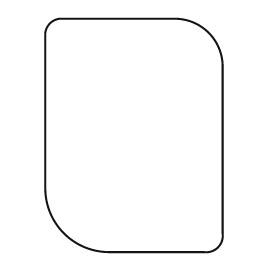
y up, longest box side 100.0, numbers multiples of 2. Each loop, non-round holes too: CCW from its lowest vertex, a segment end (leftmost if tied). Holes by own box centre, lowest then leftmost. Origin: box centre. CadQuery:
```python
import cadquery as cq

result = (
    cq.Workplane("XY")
    .moveTo(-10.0, -50.0)
    .lineTo(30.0, -50.0)
    .threePointArc((36.0, -48.0), (38.0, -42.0))
    .lineTo(38.0, 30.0)
    .threePointArc((32.0, 44.0), (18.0, 50.0))
    .lineTo(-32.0, 50.0)
    .threePointArc((-36.0, 48.0), (-38.0, 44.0))
    .lineTo(-38.0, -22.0)
    .threePointArc((-30.0, -42.0), (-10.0, -50.0))
    .close()
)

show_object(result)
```